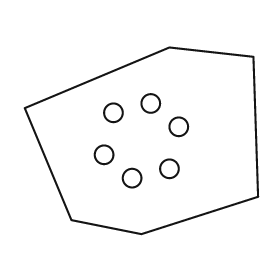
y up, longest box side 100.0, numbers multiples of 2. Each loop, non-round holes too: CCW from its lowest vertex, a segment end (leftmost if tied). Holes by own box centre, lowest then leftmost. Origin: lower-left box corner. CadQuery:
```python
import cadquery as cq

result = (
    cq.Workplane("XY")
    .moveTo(50.0, 0.0)
    .lineTo(100.0, 16.0)
    .lineTo(98.0, 76.0)
    .lineTo(62.0, 80.0)
    .lineTo(0.0, 54.0)
    .lineTo(20.0, 6.0)
    .close()
    .moveTo(46.0, 24.0)
    .circle(4.0)
    .moveTo(62.0, 28.0)
    .circle(4.0)
    .moveTo(34.0, 34.0)
    .circle(4.0)
    .moveTo(66.0, 46.0)
    .circle(4.0)
    .moveTo(38.0, 52.0)
    .circle(4.0)
    .moveTo(54.0, 56.0)
    .circle(4.0)
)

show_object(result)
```